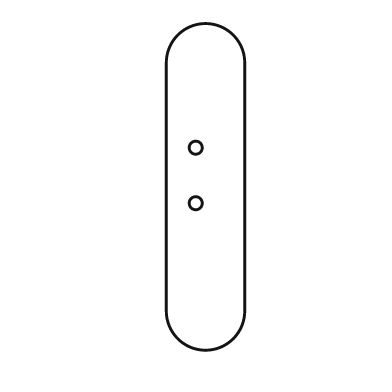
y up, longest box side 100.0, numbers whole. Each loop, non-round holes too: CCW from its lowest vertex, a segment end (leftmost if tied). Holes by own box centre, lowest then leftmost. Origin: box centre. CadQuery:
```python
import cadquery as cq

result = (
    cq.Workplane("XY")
    .moveTo(-12.0, -38.0)
    .threePointArc((0.0, -50.0), (12.0, -38.0))
    .lineTo(12.0, 38.0)
    .threePointArc((0.0, 50.0), (-12.0, 38.0))
    .close()
    .moveTo(-3.0, -5.0)
    .circle(2.0)
    .moveTo(-3.0, 12.0)
    .circle(2.0)
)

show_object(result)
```